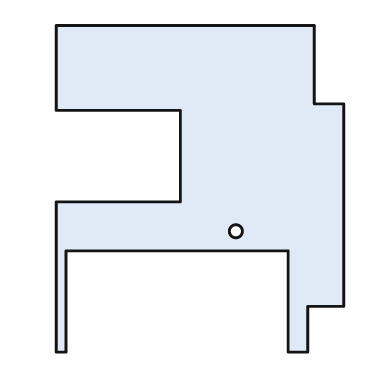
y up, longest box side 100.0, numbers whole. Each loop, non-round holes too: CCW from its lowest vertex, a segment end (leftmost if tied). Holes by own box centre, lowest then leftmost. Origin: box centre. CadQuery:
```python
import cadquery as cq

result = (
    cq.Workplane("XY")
    .moveTo(-44.0, -50.0)
    .lineTo(-41.0, -50.0)
    .lineTo(-41.0, -19.0)
    .lineTo(27.0, -19.0)
    .lineTo(27.0, -50.0)
    .lineTo(33.0, -50.0)
    .lineTo(33.0, -36.0)
    .lineTo(44.0, -36.0)
    .lineTo(44.0, 26.0)
    .lineTo(35.0, 26.0)
    .lineTo(35.0, 50.0)
    .lineTo(-44.0, 50.0)
    .lineTo(-44.0, 24.0)
    .lineTo(-6.0, 24.0)
    .lineTo(-6.0, -4.0)
    .lineTo(-44.0, -4.0)
    .close()
    .moveTo(11.0, -13.0)
    .circle(2.0)
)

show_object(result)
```